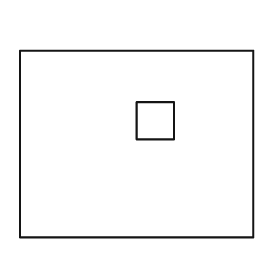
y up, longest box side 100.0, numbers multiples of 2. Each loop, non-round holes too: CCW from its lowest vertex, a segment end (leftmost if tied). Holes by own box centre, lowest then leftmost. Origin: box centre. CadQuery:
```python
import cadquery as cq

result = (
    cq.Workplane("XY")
    .moveTo(-50.0, -40.0)
    .lineTo(50.0, -40.0)
    .lineTo(50.0, 40.0)
    .lineTo(-50.0, 40.0)
    .close()
    .moveTo(0.0, 2.0)
    .lineTo(16.0, 2.0)
    .lineTo(16.0, 18.0)
    .lineTo(0.0, 18.0)
    .close()
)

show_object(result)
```